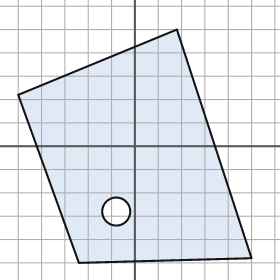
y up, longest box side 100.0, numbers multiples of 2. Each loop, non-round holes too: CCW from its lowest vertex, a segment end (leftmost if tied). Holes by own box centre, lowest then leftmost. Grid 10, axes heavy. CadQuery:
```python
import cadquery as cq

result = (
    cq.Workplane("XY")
    .moveTo(-24.0, -50.0)
    .lineTo(50.0, -48.0)
    .lineTo(18.0, 50.0)
    .lineTo(-50.0, 22.0)
    .close()
    .moveTo(-8.0, -28.0)
    .circle(6.0)
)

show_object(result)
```